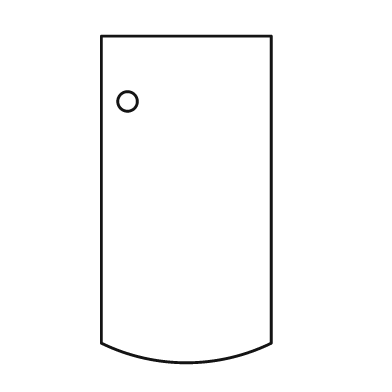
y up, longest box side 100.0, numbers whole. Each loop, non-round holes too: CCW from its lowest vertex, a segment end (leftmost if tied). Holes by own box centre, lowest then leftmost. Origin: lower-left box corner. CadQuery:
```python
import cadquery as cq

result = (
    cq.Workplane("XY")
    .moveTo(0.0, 6.0)
    .threePointArc((26.0, 0.0), (52.0, 6.0))
    .lineTo(52.0, 100.0)
    .lineTo(0.0, 100.0)
    .close()
    .moveTo(8.0, 80.0)
    .circle(3.0)
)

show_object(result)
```